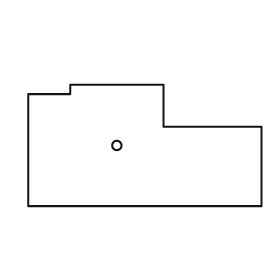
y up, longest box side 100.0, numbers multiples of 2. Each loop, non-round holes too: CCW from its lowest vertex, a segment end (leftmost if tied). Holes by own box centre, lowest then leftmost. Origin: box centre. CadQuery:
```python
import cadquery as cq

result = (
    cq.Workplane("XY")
    .moveTo(-50.0, -26.0)
    .lineTo(50.0, -26.0)
    .lineTo(50.0, 8.0)
    .lineTo(8.0, 8.0)
    .lineTo(8.0, 26.0)
    .lineTo(-32.0, 26.0)
    .lineTo(-32.0, 22.0)
    .lineTo(-50.0, 22.0)
    .close()
    .moveTo(-12.0, 0.0)
    .circle(2.0)
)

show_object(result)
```